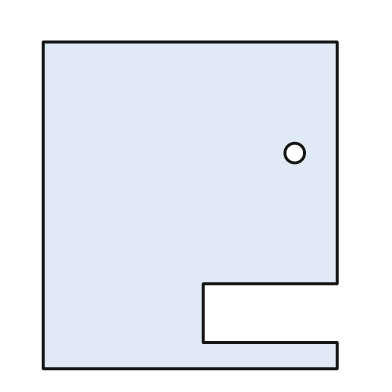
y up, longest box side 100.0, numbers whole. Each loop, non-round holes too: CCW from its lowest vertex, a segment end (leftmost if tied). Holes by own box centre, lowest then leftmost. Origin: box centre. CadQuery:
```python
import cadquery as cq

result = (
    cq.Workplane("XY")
    .moveTo(-45.0, -50.0)
    .lineTo(45.0, -50.0)
    .lineTo(45.0, -42.0)
    .lineTo(4.0, -42.0)
    .lineTo(4.0, -24.0)
    .lineTo(45.0, -24.0)
    .lineTo(45.0, 50.0)
    .lineTo(-45.0, 50.0)
    .close()
    .moveTo(32.0, 16.0)
    .circle(3.0)
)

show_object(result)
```